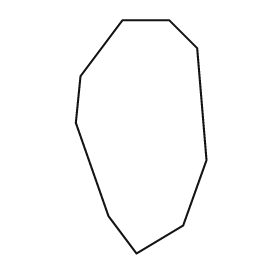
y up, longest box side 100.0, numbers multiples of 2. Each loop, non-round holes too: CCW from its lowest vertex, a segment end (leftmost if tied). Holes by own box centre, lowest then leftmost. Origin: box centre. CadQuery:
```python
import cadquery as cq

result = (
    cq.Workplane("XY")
    .moveTo(-2.0, -50.0)
    .lineTo(18.0, -38.0)
    .lineTo(28.0, -10.0)
    .lineTo(24.0, 38.0)
    .lineTo(12.0, 50.0)
    .lineTo(-8.0, 50.0)
    .lineTo(-26.0, 26.0)
    .lineTo(-28.0, 6.0)
    .lineTo(-14.0, -34.0)
    .close()
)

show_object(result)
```